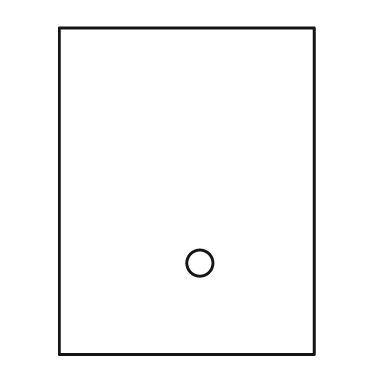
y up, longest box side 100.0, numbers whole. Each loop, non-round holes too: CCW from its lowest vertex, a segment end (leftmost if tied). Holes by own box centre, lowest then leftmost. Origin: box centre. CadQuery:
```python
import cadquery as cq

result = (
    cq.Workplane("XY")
    .moveTo(-39.0, -50.0)
    .lineTo(39.0, -50.0)
    .lineTo(39.0, 50.0)
    .lineTo(-39.0, 50.0)
    .close()
    .moveTo(4.0, -22.0)
    .circle(4.0)
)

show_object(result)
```